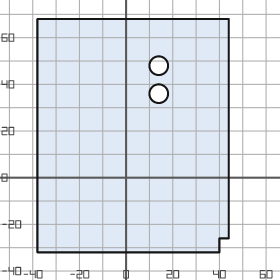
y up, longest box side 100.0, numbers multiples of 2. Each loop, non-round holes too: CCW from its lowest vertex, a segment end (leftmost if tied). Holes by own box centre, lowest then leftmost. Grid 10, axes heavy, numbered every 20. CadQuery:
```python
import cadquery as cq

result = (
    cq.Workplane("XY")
    .moveTo(-38.0, -32.0)
    .lineTo(40.0, -32.0)
    .lineTo(40.0, -26.0)
    .lineTo(44.0, -26.0)
    .lineTo(44.0, 68.0)
    .lineTo(-38.0, 68.0)
    .close()
    .moveTo(14.0, 36.0)
    .circle(4.0)
    .moveTo(14.0, 48.0)
    .circle(4.0)
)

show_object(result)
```